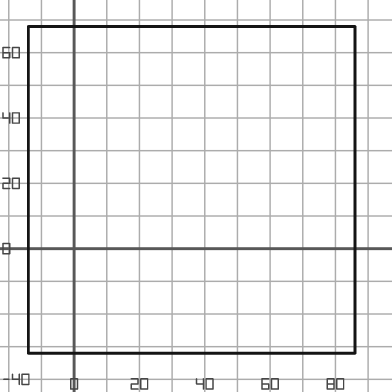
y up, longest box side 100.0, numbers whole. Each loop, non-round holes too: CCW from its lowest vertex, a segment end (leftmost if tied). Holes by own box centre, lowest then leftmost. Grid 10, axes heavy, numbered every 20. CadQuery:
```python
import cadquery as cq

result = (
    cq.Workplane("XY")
    .moveTo(-14.0, -32.0)
    .lineTo(86.0, -32.0)
    .lineTo(86.0, 68.0)
    .lineTo(-14.0, 68.0)
    .close()
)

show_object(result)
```